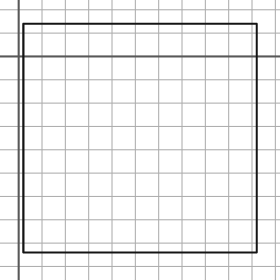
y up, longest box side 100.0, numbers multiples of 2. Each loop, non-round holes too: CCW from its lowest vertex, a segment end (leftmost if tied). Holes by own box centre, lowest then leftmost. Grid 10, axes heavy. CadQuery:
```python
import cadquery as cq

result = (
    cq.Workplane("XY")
    .moveTo(2.0, -84.0)
    .lineTo(102.0, -84.0)
    .lineTo(102.0, 14.0)
    .lineTo(2.0, 14.0)
    .close()
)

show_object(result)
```